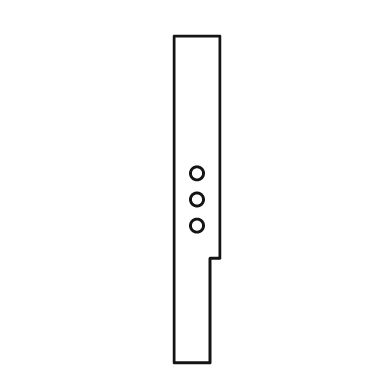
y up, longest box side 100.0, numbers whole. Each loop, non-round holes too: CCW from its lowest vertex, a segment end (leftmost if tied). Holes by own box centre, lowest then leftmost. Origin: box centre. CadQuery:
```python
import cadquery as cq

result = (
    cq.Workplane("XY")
    .moveTo(-7.0, -50.0)
    .lineTo(4.0, -50.0)
    .lineTo(4.0, -18.0)
    .lineTo(7.0, -18.0)
    .lineTo(7.0, 50.0)
    .lineTo(-7.0, 50.0)
    .close()
    .moveTo(0.0, -8.0)
    .circle(2.0)
    .moveTo(0.0, 0.0)
    .circle(2.0)
    .moveTo(0.0, 8.0)
    .circle(2.0)
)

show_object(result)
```